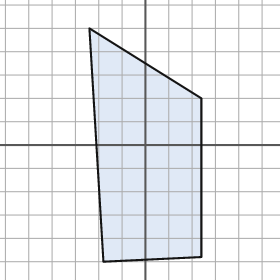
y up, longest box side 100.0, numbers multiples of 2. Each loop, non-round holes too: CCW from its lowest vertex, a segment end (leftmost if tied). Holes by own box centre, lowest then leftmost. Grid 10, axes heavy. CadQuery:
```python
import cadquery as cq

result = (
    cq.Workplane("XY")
    .moveTo(-18.0, -50.0)
    .lineTo(24.0, -48.0)
    .lineTo(24.0, 20.0)
    .lineTo(-24.0, 50.0)
    .close()
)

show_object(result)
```